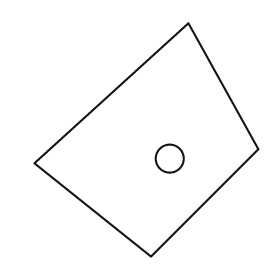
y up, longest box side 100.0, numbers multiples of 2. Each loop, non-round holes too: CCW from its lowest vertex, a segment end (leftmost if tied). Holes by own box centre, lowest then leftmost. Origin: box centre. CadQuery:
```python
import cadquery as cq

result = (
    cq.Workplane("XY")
    .moveTo(2.0, -50.0)
    .lineTo(48.0, -4.0)
    .lineTo(18.0, 50.0)
    .lineTo(-48.0, -10.0)
    .close()
    .moveTo(10.0, -8.0)
    .circle(6.0)
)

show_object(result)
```